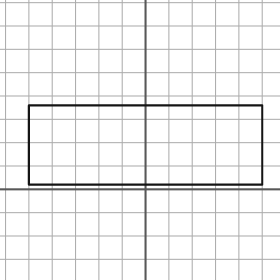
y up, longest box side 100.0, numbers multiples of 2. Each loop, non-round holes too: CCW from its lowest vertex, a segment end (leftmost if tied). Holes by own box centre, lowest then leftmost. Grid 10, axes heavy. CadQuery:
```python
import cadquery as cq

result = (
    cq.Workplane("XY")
    .moveTo(-50.0, 2.0)
    .lineTo(50.0, 2.0)
    .lineTo(50.0, 36.0)
    .lineTo(-50.0, 36.0)
    .close()
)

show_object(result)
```